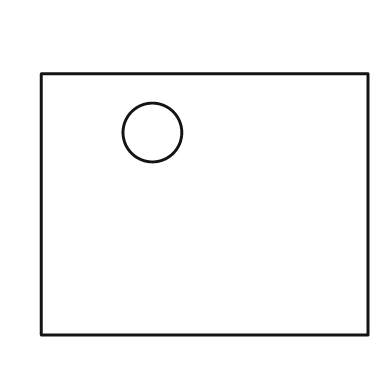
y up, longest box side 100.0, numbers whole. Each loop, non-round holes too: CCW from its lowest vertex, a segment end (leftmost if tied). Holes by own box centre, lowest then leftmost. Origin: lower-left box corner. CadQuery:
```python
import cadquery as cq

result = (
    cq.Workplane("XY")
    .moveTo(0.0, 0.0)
    .lineTo(100.0, 0.0)
    .lineTo(100.0, 80.0)
    .lineTo(0.0, 80.0)
    .close()
    .moveTo(34.0, 62.0)
    .circle(9.0)
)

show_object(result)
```